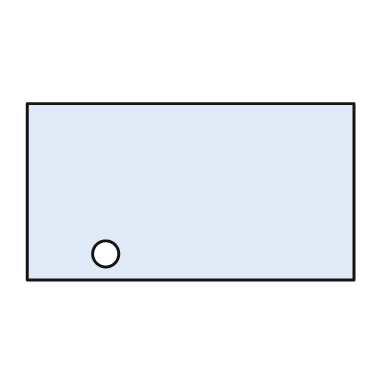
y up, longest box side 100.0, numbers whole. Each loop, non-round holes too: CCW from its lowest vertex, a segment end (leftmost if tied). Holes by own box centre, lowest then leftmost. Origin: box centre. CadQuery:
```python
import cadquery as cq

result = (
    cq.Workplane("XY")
    .moveTo(-50.0, -27.0)
    .lineTo(50.0, -27.0)
    .lineTo(50.0, 27.0)
    .lineTo(-50.0, 27.0)
    .close()
    .moveTo(-26.0, -19.0)
    .circle(4.0)
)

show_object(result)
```